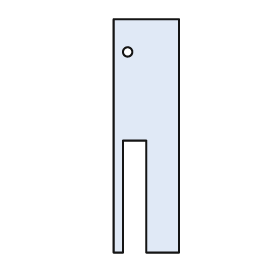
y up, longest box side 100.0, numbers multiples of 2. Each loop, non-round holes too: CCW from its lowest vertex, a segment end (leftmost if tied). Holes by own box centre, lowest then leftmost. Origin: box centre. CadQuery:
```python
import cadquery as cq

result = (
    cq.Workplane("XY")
    .moveTo(-14.0, -50.0)
    .lineTo(-10.0, -50.0)
    .lineTo(-10.0, -2.0)
    .lineTo(0.0, -2.0)
    .lineTo(0.0, -50.0)
    .lineTo(14.0, -50.0)
    .lineTo(14.0, 50.0)
    .lineTo(-14.0, 50.0)
    .close()
    .moveTo(-8.0, 36.0)
    .circle(2.0)
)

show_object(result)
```